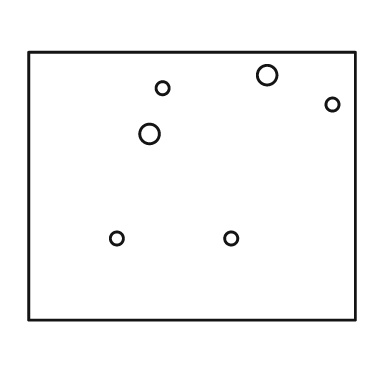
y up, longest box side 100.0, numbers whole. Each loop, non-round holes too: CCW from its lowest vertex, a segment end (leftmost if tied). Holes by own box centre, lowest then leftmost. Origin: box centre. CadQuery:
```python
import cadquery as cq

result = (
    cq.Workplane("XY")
    .moveTo(-50.0, -41.0)
    .lineTo(50.0, -41.0)
    .lineTo(50.0, 41.0)
    .lineTo(-50.0, 41.0)
    .close()
    .moveTo(-23.0, -16.0)
    .circle(2.0)
    .moveTo(12.0, -16.0)
    .circle(2.0)
    .moveTo(-13.0, 16.0)
    .circle(3.0)
    .moveTo(43.0, 25.0)
    .circle(2.0)
    .moveTo(-9.0, 30.0)
    .circle(2.0)
    .moveTo(23.0, 34.0)
    .circle(3.0)
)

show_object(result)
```